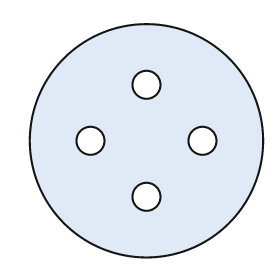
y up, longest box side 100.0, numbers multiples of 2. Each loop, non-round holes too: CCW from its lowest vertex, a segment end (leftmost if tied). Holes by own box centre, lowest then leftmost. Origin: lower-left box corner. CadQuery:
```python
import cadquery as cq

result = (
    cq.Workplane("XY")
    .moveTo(50.0, 50.0)
    .circle(50.0)
    .moveTo(50.0, 26.0)
    .circle(6.0)
    .moveTo(26.0, 50.0)
    .circle(6.0)
    .moveTo(74.0, 50.0)
    .circle(6.0)
    .moveTo(50.0, 74.0)
    .circle(6.0)
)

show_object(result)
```